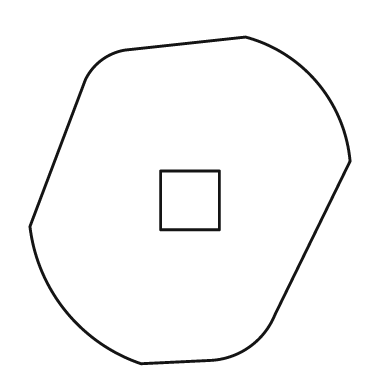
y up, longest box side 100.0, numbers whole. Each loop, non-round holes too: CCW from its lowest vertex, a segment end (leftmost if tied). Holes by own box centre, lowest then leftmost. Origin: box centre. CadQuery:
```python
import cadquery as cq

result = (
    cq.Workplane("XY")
    .moveTo(-15.0, -50.0)
    .lineTo(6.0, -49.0)
    .threePointArc((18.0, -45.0), (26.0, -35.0))
    .lineTo(49.0, 12.0)
    .threePointArc((39.0, 36.0), (17.0, 50.0))
    .lineTo(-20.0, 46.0)
    .threePointArc((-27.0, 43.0), (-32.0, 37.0))
    .lineTo(-49.0, -8.0)
    .threePointArc((-38.0, -34.0), (-15.0, -50.0))
    .close()
    .moveTo(-9.0, -9.0)
    .lineTo(9.0, -9.0)
    .lineTo(9.0, 9.0)
    .lineTo(-9.0, 9.0)
    .close()
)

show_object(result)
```